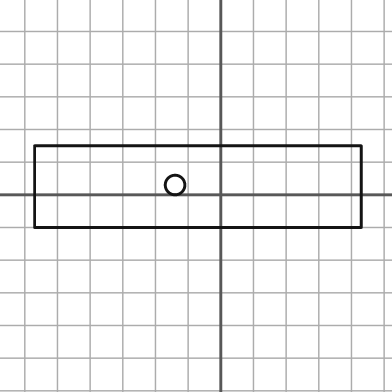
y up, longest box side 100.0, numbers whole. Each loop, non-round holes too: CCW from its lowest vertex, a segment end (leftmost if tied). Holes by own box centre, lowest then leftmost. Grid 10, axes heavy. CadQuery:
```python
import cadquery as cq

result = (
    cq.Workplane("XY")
    .moveTo(-57.0, -10.0)
    .lineTo(43.0, -10.0)
    .lineTo(43.0, 15.0)
    .lineTo(-57.0, 15.0)
    .close()
    .moveTo(-14.0, 3.0)
    .circle(3.0)
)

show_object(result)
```